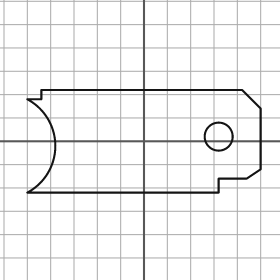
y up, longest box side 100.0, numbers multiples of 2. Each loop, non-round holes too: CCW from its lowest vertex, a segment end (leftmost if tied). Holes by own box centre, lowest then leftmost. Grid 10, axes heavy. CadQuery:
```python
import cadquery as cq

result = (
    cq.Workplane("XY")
    .moveTo(-50.0, -22.0)
    .lineTo(32.0, -22.0)
    .lineTo(32.0, -16.0)
    .lineTo(44.0, -16.0)
    .lineTo(50.0, -12.0)
    .lineTo(50.0, 14.0)
    .lineTo(42.0, 22.0)
    .lineTo(-44.0, 22.0)
    .lineTo(-44.0, 18.0)
    .lineTo(-50.0, 18.0)
    .threePointArc((-38.0, -2.0), (-50.0, -22.0))
    .close()
    .moveTo(32.0, 2.0)
    .circle(6.0)
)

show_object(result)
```